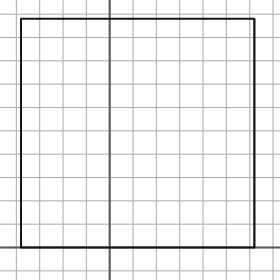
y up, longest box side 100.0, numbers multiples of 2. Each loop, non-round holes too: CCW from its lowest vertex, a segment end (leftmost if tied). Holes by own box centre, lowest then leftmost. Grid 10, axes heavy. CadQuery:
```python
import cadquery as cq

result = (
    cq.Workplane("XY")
    .moveTo(-38.0, 0.0)
    .lineTo(62.0, 0.0)
    .lineTo(62.0, 98.0)
    .lineTo(-38.0, 98.0)
    .close()
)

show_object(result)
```